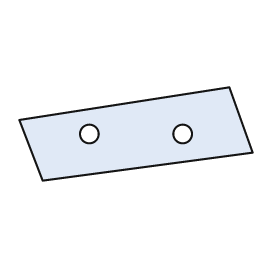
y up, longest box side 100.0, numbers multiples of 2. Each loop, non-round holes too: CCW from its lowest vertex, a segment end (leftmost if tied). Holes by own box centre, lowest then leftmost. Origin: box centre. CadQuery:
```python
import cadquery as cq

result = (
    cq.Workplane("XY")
    .moveTo(-40.0, -20.0)
    .lineTo(50.0, -8.0)
    .lineTo(40.0, 20.0)
    .lineTo(-50.0, 6.0)
    .close()
    .moveTo(-20.0, 0.0)
    .circle(4.0)
    .moveTo(20.0, 0.0)
    .circle(4.0)
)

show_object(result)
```